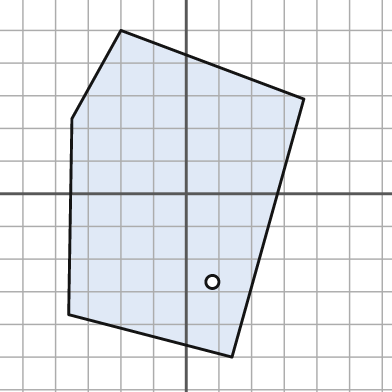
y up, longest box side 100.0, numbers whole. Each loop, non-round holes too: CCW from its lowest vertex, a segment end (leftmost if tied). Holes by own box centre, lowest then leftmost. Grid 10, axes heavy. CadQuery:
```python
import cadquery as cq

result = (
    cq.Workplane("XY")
    .moveTo(14.0, -50.0)
    .lineTo(36.0, 29.0)
    .lineTo(-20.0, 50.0)
    .lineTo(-35.0, 23.0)
    .lineTo(-36.0, -37.0)
    .close()
    .moveTo(8.0, -27.0)
    .circle(2.0)
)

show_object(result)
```